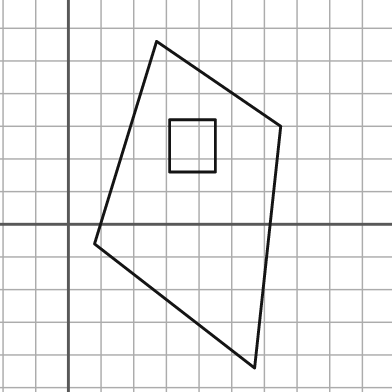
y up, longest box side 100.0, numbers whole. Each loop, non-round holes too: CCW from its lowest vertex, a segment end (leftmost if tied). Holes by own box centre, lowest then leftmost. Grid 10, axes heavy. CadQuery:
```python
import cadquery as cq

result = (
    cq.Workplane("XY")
    .moveTo(57.0, -44.0)
    .lineTo(65.0, 30.0)
    .lineTo(27.0, 56.0)
    .lineTo(8.0, -6.0)
    .close()
    .moveTo(31.0, 16.0)
    .lineTo(45.0, 16.0)
    .lineTo(45.0, 32.0)
    .lineTo(31.0, 32.0)
    .close()
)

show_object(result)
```